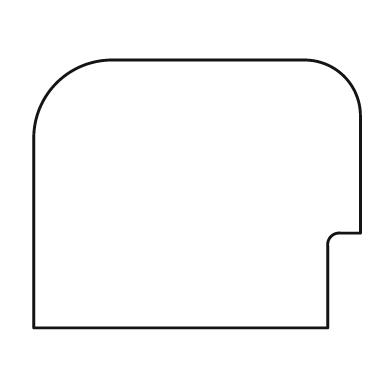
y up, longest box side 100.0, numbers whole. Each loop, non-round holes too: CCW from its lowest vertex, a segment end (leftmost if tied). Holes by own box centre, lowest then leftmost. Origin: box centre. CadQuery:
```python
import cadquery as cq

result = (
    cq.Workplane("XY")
    .moveTo(-50.0, -41.0)
    .lineTo(40.0, -41.0)
    .lineTo(40.0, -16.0)
    .threePointArc((41.0, -13.0), (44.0, -12.0))
    .lineTo(50.0, -12.0)
    .lineTo(50.0, 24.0)
    .threePointArc((45.0, 36.0), (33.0, 41.0))
    .lineTo(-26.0, 41.0)
    .threePointArc((-43.0, 34.0), (-50.0, 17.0))
    .close()
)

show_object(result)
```